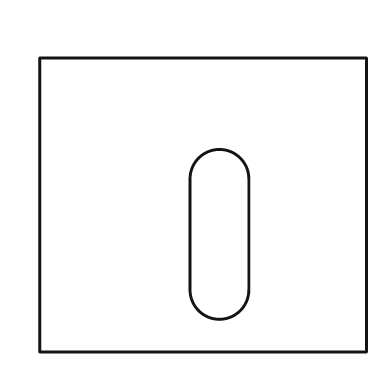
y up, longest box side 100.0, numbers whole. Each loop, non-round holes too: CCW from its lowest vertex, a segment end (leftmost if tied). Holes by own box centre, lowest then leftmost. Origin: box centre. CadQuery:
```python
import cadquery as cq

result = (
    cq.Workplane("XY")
    .moveTo(-50.0, -45.0)
    .lineTo(50.0, -45.0)
    .lineTo(50.0, 45.0)
    .lineTo(-50.0, 45.0)
    .close()
    .moveTo(-4.0, -26.0)
    .threePointArc((5.0, -35.0), (14.0, -26.0))
    .lineTo(14.0, 8.0)
    .threePointArc((5.0, 17.0), (-4.0, 8.0))
    .close()
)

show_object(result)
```